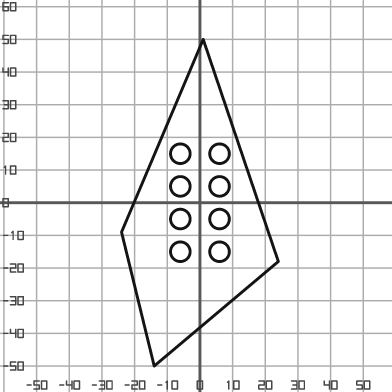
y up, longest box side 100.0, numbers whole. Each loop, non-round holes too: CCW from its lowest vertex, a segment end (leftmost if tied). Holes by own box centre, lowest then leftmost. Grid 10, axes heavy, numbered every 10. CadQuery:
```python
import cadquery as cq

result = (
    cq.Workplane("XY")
    .moveTo(-14.0, -50.0)
    .lineTo(24.0, -18.0)
    .lineTo(1.0, 50.0)
    .lineTo(-24.0, -9.0)
    .close()
    .moveTo(-6.0, -15.0)
    .circle(3.0)
    .moveTo(6.0, -15.0)
    .circle(3.0)
    .moveTo(-6.0, -5.0)
    .circle(3.0)
    .moveTo(6.0, -5.0)
    .circle(3.0)
    .moveTo(-6.0, 5.0)
    .circle(3.0)
    .moveTo(6.0, 5.0)
    .circle(3.0)
    .moveTo(-6.0, 15.0)
    .circle(3.0)
    .moveTo(6.0, 15.0)
    .circle(3.0)
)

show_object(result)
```